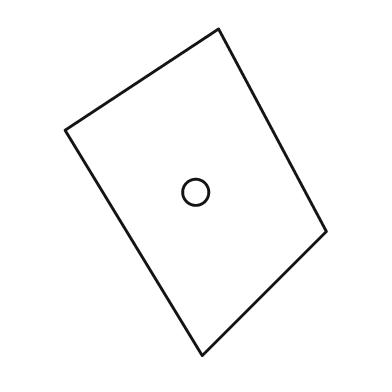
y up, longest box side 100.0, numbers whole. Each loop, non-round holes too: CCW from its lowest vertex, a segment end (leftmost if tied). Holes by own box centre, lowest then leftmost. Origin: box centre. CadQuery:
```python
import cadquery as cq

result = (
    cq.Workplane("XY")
    .moveTo(2.0, -50.0)
    .lineTo(40.0, -12.0)
    .lineTo(7.0, 50.0)
    .lineTo(-40.0, 19.0)
    .close()
    .moveTo(0.0, 0.0)
    .circle(4.0)
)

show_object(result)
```